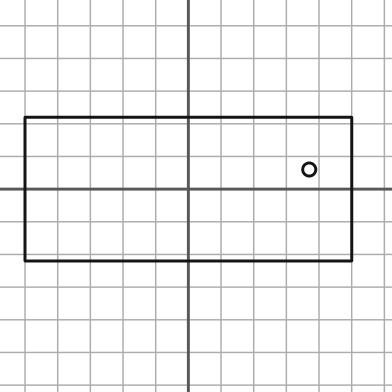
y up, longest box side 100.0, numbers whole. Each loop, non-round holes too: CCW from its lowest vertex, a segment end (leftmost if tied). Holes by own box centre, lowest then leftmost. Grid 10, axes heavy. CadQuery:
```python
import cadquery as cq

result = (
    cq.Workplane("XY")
    .moveTo(-50.0, -22.0)
    .lineTo(50.0, -22.0)
    .lineTo(50.0, 22.0)
    .lineTo(-50.0, 22.0)
    .close()
    .moveTo(37.0, 6.0)
    .circle(2.0)
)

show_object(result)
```